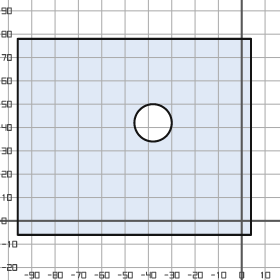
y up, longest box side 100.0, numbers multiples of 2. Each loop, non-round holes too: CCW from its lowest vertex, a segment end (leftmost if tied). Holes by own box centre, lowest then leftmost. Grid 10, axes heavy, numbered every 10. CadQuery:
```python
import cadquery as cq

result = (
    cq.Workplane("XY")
    .moveTo(-96.0, -6.0)
    .lineTo(4.0, -6.0)
    .lineTo(4.0, 78.0)
    .lineTo(-96.0, 78.0)
    .close()
    .moveTo(-38.0, 42.0)
    .circle(8.0)
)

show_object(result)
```